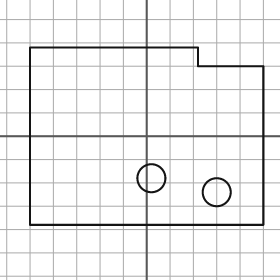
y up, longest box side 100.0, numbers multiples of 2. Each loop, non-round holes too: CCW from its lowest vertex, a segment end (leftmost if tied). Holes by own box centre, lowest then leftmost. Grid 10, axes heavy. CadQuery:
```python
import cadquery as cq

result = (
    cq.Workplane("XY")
    .moveTo(-50.0, -38.0)
    .lineTo(50.0, -38.0)
    .lineTo(50.0, 30.0)
    .lineTo(22.0, 30.0)
    .lineTo(22.0, 38.0)
    .lineTo(-50.0, 38.0)
    .close()
    .moveTo(30.0, -24.0)
    .circle(6.0)
    .moveTo(2.0, -18.0)
    .circle(6.0)
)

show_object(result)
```